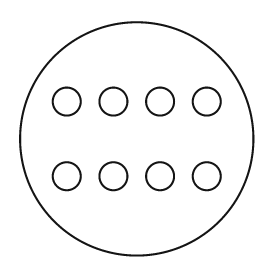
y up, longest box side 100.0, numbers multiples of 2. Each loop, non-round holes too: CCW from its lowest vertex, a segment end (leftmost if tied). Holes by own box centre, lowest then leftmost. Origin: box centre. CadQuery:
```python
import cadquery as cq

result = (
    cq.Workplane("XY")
    .moveTo(0.0, 0.0)
    .circle(50.0)
    .moveTo(-30.0, -16.0)
    .circle(6.0)
    .moveTo(-10.0, -16.0)
    .circle(6.0)
    .moveTo(10.0, -16.0)
    .circle(6.0)
    .moveTo(30.0, -16.0)
    .circle(6.0)
    .moveTo(-30.0, 16.0)
    .circle(6.0)
    .moveTo(-10.0, 16.0)
    .circle(6.0)
    .moveTo(10.0, 16.0)
    .circle(6.0)
    .moveTo(30.0, 16.0)
    .circle(6.0)
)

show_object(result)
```